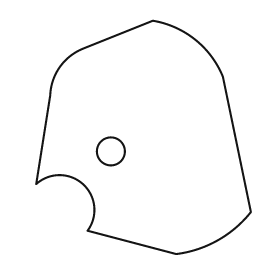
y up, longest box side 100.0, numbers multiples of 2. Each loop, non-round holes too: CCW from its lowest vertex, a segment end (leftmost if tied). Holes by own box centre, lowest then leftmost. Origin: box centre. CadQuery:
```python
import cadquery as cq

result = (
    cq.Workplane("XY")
    .moveTo(14.0, -50.0)
    .threePointArc((32.0, -44.0), (46.0, -32.0))
    .lineTo(34.0, 26.0)
    .threePointArc((22.0, 42.0), (4.0, 50.0))
    .lineTo(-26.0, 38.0)
    .threePointArc((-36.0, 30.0), (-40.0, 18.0))
    .lineTo(-46.0, -20.0)
    .threePointArc((-26.0, -20.0), (-24.0, -40.0))
    .close()
    .moveTo(-14.0, -6.0)
    .circle(6.0)
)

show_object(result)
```